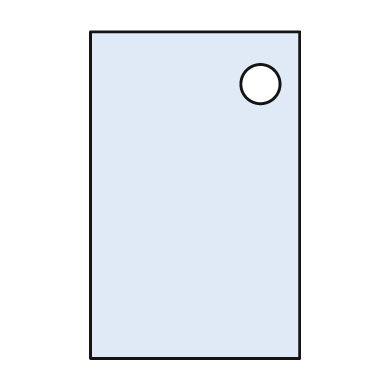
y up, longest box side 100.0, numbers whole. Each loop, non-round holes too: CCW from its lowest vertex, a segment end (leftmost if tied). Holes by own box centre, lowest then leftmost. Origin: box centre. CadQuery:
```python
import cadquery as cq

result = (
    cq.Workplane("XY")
    .moveTo(-32.0, -50.0)
    .lineTo(32.0, -50.0)
    .lineTo(32.0, 50.0)
    .lineTo(-32.0, 50.0)
    .close()
    .moveTo(20.0, 34.0)
    .circle(6.0)
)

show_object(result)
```